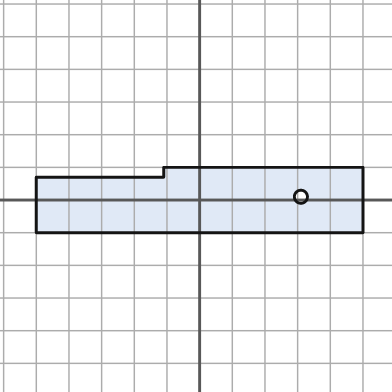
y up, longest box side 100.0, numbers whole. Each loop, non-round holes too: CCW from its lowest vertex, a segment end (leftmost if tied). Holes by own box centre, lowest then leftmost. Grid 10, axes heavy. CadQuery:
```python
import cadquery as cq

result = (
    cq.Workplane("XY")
    .moveTo(-50.0, -10.0)
    .lineTo(50.0, -10.0)
    .lineTo(50.0, 10.0)
    .lineTo(-11.0, 10.0)
    .lineTo(-11.0, 7.0)
    .lineTo(-50.0, 7.0)
    .close()
    .moveTo(31.0, 1.0)
    .circle(2.0)
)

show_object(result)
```